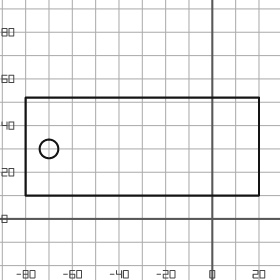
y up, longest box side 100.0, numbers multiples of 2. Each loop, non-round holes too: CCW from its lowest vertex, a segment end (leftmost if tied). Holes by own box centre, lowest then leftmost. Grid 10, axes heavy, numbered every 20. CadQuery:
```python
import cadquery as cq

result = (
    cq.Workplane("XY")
    .moveTo(-80.0, 10.0)
    .lineTo(20.0, 10.0)
    .lineTo(20.0, 52.0)
    .lineTo(-80.0, 52.0)
    .close()
    .moveTo(-70.0, 30.0)
    .circle(4.0)
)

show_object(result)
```